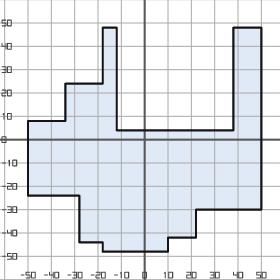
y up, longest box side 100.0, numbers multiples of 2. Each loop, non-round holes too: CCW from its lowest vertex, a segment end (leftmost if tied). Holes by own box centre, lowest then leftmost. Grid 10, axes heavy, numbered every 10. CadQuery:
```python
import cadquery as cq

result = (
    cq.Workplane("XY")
    .moveTo(-18.0, -48.0)
    .lineTo(10.0, -48.0)
    .lineTo(10.0, -42.0)
    .lineTo(22.0, -42.0)
    .lineTo(22.0, -30.0)
    .lineTo(50.0, -30.0)
    .lineTo(50.0, 48.0)
    .lineTo(38.0, 48.0)
    .lineTo(38.0, 4.0)
    .lineTo(-12.0, 4.0)
    .lineTo(-12.0, 48.0)
    .lineTo(-18.0, 48.0)
    .lineTo(-18.0, 24.0)
    .lineTo(-34.0, 24.0)
    .lineTo(-34.0, 8.0)
    .lineTo(-50.0, 8.0)
    .lineTo(-50.0, -24.0)
    .lineTo(-28.0, -24.0)
    .lineTo(-28.0, -44.0)
    .lineTo(-18.0, -44.0)
    .close()
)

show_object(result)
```